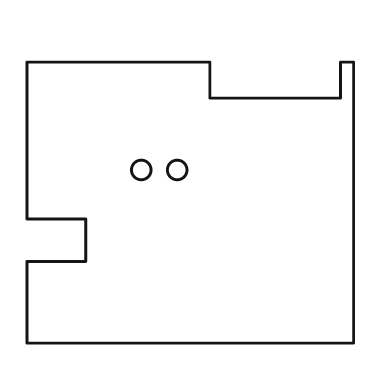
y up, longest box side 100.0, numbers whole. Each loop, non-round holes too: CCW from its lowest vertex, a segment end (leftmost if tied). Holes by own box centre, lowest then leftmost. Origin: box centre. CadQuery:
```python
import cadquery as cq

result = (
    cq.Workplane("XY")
    .moveTo(-50.0, -43.0)
    .lineTo(50.0, -43.0)
    .lineTo(50.0, 43.0)
    .lineTo(46.0, 43.0)
    .lineTo(46.0, 32.0)
    .lineTo(6.0, 32.0)
    .lineTo(6.0, 43.0)
    .lineTo(-50.0, 43.0)
    .lineTo(-50.0, -5.0)
    .lineTo(-32.0, -5.0)
    .lineTo(-32.0, -18.0)
    .lineTo(-50.0, -18.0)
    .close()
    .moveTo(-15.0, 10.0)
    .circle(3.0)
    .moveTo(-4.0, 10.0)
    .circle(3.0)
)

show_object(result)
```